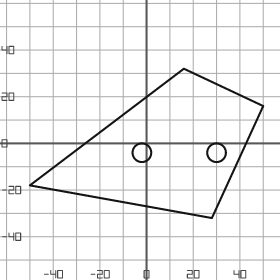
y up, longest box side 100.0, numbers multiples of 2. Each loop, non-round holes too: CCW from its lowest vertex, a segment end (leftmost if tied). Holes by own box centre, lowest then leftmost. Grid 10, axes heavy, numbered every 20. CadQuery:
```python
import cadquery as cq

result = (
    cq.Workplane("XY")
    .moveTo(28.0, -32.0)
    .lineTo(50.0, 16.0)
    .lineTo(16.0, 32.0)
    .lineTo(-50.0, -18.0)
    .close()
    .moveTo(-2.0, -4.0)
    .circle(4.0)
    .moveTo(30.0, -4.0)
    .circle(4.0)
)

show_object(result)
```